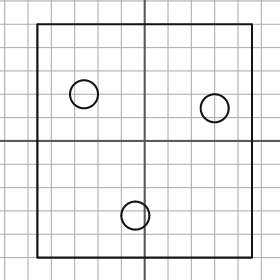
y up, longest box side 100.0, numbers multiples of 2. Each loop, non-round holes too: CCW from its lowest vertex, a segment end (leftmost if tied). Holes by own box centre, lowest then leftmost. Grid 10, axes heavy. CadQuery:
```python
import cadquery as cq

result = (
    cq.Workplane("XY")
    .moveTo(-46.0, -50.0)
    .lineTo(46.0, -50.0)
    .lineTo(46.0, 50.0)
    .lineTo(-46.0, 50.0)
    .close()
    .moveTo(-4.0, -32.0)
    .circle(6.0)
    .moveTo(30.0, 14.0)
    .circle(6.0)
    .moveTo(-26.0, 20.0)
    .circle(6.0)
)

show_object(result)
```